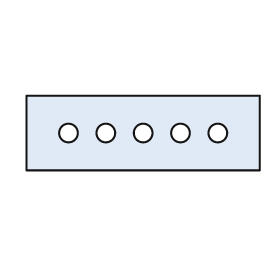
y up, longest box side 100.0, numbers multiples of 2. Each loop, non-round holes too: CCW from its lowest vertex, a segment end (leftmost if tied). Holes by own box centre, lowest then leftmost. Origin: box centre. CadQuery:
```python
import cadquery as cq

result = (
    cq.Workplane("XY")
    .moveTo(-50.0, -16.0)
    .lineTo(50.0, -16.0)
    .lineTo(50.0, 16.0)
    .lineTo(-50.0, 16.0)
    .close()
    .moveTo(-32.0, 0.0)
    .circle(4.0)
    .moveTo(-16.0, 0.0)
    .circle(4.0)
    .moveTo(0.0, 0.0)
    .circle(4.0)
    .moveTo(16.0, 0.0)
    .circle(4.0)
    .moveTo(32.0, 0.0)
    .circle(4.0)
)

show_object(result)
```